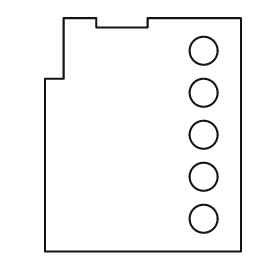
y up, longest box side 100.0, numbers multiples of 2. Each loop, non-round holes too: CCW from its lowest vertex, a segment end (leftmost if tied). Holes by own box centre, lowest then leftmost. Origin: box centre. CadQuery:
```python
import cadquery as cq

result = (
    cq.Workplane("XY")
    .moveTo(-42.0, -50.0)
    .lineTo(42.0, -50.0)
    .lineTo(42.0, 50.0)
    .lineTo(2.0, 50.0)
    .lineTo(2.0, 46.0)
    .lineTo(-20.0, 46.0)
    .lineTo(-20.0, 50.0)
    .lineTo(-34.0, 50.0)
    .lineTo(-34.0, 24.0)
    .lineTo(-42.0, 24.0)
    .close()
    .moveTo(26.0, -36.0)
    .circle(6.0)
    .moveTo(26.0, -18.0)
    .circle(6.0)
    .moveTo(26.0, 0.0)
    .circle(6.0)
    .moveTo(26.0, 18.0)
    .circle(6.0)
    .moveTo(26.0, 36.0)
    .circle(6.0)
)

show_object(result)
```